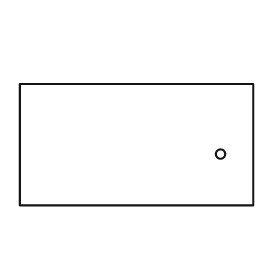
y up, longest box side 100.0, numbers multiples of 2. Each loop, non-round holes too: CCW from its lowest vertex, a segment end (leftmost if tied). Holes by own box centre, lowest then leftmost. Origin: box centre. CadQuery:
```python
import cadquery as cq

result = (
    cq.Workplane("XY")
    .moveTo(-50.0, -26.0)
    .lineTo(50.0, -26.0)
    .lineTo(50.0, 26.0)
    .lineTo(-50.0, 26.0)
    .close()
    .moveTo(36.0, -4.0)
    .circle(2.0)
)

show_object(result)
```